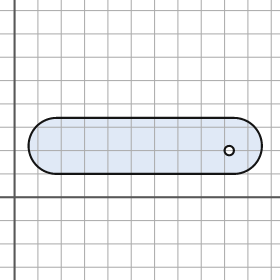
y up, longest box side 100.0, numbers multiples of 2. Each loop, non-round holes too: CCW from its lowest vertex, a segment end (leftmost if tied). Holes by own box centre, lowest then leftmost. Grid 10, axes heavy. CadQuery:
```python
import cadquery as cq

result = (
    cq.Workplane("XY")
    .moveTo(18.0, 10.0)
    .lineTo(94.0, 10.0)
    .threePointArc((106.0, 22.0), (94.0, 34.0))
    .lineTo(18.0, 34.0)
    .threePointArc((6.0, 22.0), (18.0, 10.0))
    .close()
    .moveTo(92.0, 20.0)
    .circle(2.0)
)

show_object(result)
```